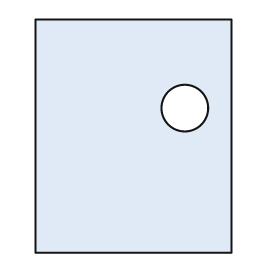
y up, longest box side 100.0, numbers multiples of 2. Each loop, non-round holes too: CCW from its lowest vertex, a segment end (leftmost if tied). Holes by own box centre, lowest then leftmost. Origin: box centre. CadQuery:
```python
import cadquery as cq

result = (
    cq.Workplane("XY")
    .moveTo(-42.0, -50.0)
    .lineTo(42.0, -50.0)
    .lineTo(42.0, 50.0)
    .lineTo(-42.0, 50.0)
    .close()
    .moveTo(22.0, 12.0)
    .circle(10.0)
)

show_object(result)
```